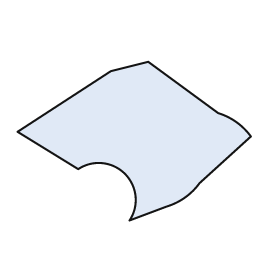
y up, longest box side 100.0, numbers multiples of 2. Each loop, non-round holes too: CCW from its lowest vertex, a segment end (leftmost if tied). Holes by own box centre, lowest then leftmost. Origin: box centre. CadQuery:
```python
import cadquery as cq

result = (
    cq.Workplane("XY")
    .moveTo(-2.0, -34.0)
    .lineTo(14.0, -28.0)
    .threePointArc((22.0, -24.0), (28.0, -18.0))
    .lineTo(50.0, 2.0)
    .threePointArc((44.0, 8.0), (36.0, 12.0))
    .lineTo(6.0, 34.0)
    .lineTo(-10.0, 30.0)
    .lineTo(-50.0, 4.0)
    .lineTo(-24.0, -12.0)
    .threePointArc((-4.0, -14.0), (-2.0, -34.0))
    .close()
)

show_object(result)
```